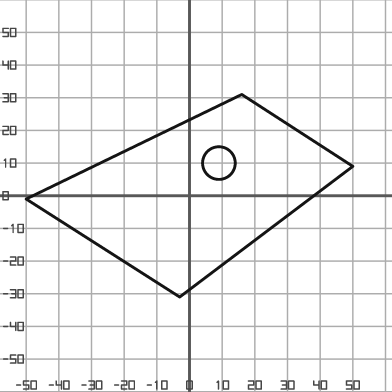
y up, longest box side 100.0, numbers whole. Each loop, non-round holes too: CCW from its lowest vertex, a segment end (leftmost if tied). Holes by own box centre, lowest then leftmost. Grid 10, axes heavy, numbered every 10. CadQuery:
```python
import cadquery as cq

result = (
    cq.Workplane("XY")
    .moveTo(-3.0, -31.0)
    .lineTo(50.0, 9.0)
    .lineTo(16.0, 31.0)
    .lineTo(-50.0, -1.0)
    .close()
    .moveTo(9.0, 10.0)
    .circle(5.0)
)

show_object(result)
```